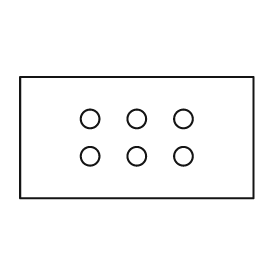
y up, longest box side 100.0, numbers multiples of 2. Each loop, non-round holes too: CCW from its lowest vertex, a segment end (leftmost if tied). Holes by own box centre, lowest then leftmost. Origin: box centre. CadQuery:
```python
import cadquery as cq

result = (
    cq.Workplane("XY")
    .moveTo(-50.0, -26.0)
    .lineTo(50.0, -26.0)
    .lineTo(50.0, 26.0)
    .lineTo(-50.0, 26.0)
    .close()
    .moveTo(-20.0, -8.0)
    .circle(4.0)
    .moveTo(0.0, -8.0)
    .circle(4.0)
    .moveTo(20.0, -8.0)
    .circle(4.0)
    .moveTo(-20.0, 8.0)
    .circle(4.0)
    .moveTo(0.0, 8.0)
    .circle(4.0)
    .moveTo(20.0, 8.0)
    .circle(4.0)
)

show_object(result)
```